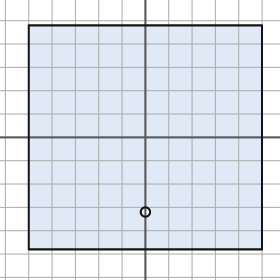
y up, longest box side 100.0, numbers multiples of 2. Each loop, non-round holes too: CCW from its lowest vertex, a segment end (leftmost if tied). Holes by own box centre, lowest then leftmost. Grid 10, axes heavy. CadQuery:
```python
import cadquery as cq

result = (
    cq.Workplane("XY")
    .moveTo(-50.0, -48.0)
    .lineTo(50.0, -48.0)
    .lineTo(50.0, 48.0)
    .lineTo(-50.0, 48.0)
    .close()
    .moveTo(0.0, -32.0)
    .circle(2.0)
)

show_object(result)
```